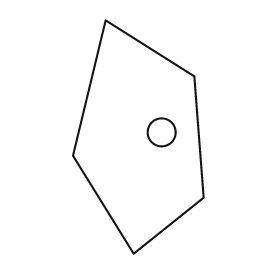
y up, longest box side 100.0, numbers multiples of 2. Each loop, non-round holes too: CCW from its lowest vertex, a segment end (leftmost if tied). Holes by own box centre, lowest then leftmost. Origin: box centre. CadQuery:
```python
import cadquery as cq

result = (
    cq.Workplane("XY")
    .moveTo(-2.0, -50.0)
    .lineTo(28.0, -26.0)
    .lineTo(24.0, 26.0)
    .lineTo(-14.0, 50.0)
    .lineTo(-28.0, -8.0)
    .close()
    .moveTo(10.0, 2.0)
    .circle(6.0)
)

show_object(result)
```